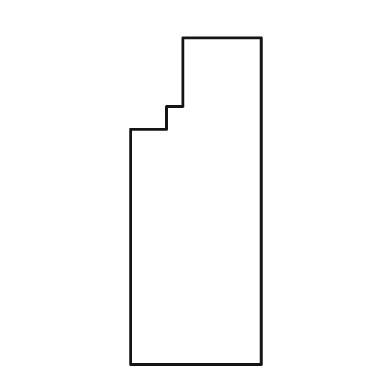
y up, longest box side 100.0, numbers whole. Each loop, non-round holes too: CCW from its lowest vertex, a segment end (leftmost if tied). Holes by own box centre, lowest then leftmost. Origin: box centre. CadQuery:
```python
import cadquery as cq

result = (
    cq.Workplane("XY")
    .moveTo(-20.0, -50.0)
    .lineTo(20.0, -50.0)
    .lineTo(20.0, 50.0)
    .lineTo(-4.0, 50.0)
    .lineTo(-4.0, 29.0)
    .lineTo(-9.0, 29.0)
    .lineTo(-9.0, 22.0)
    .lineTo(-20.0, 22.0)
    .close()
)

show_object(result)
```